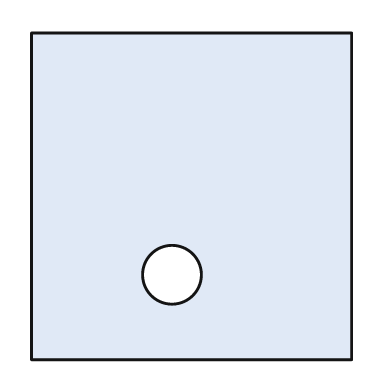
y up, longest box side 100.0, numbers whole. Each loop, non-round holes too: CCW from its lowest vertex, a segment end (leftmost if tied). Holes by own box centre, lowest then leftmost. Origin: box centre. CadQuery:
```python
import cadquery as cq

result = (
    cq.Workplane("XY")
    .moveTo(-49.0, -50.0)
    .lineTo(49.0, -50.0)
    .lineTo(49.0, 50.0)
    .lineTo(-49.0, 50.0)
    .close()
    .moveTo(-6.0, -24.0)
    .circle(9.0)
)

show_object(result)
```